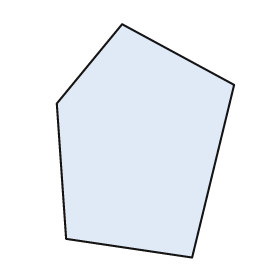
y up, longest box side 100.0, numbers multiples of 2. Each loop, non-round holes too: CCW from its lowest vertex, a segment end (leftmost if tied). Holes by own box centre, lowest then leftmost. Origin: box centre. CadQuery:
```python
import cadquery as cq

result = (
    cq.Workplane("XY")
    .moveTo(20.0, -50.0)
    .lineTo(38.0, 24.0)
    .lineTo(-10.0, 50.0)
    .lineTo(-38.0, 16.0)
    .lineTo(-34.0, -42.0)
    .close()
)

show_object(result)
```